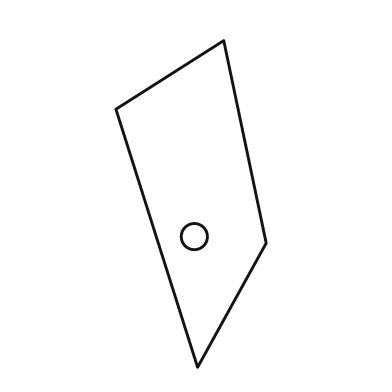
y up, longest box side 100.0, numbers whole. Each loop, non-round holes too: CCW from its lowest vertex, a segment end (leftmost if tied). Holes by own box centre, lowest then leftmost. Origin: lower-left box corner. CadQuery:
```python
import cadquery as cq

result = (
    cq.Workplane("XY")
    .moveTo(25.0, 0.0)
    .lineTo(46.0, 38.0)
    .lineTo(33.0, 100.0)
    .lineTo(0.0, 79.0)
    .close()
    .moveTo(24.0, 40.0)
    .circle(4.0)
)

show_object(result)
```